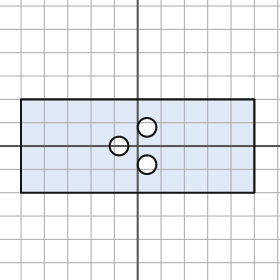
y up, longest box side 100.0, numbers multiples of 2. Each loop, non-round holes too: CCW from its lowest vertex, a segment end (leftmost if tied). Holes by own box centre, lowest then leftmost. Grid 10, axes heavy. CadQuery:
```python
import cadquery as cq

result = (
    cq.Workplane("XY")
    .moveTo(-50.0, -20.0)
    .lineTo(50.0, -20.0)
    .lineTo(50.0, 20.0)
    .lineTo(-50.0, 20.0)
    .close()
    .moveTo(4.0, -8.0)
    .circle(4.0)
    .moveTo(-8.0, 0.0)
    .circle(4.0)
    .moveTo(4.0, 8.0)
    .circle(4.0)
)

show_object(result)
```